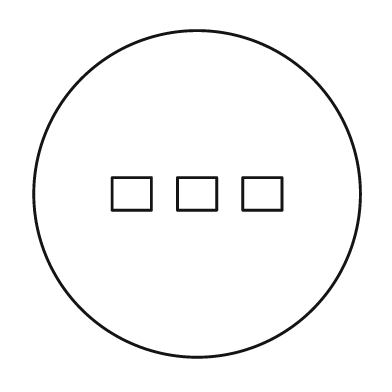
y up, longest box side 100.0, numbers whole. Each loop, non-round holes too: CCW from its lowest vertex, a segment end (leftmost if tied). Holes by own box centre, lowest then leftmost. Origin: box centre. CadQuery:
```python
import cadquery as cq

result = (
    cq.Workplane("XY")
    .moveTo(0.0, 0.0)
    .circle(50.0)
    .moveTo(-26.0, -5.0)
    .lineTo(-14.0, -5.0)
    .lineTo(-14.0, 5.0)
    .lineTo(-26.0, 5.0)
    .close()
    .moveTo(-6.0, -5.0)
    .lineTo(6.0, -5.0)
    .lineTo(6.0, 5.0)
    .lineTo(-6.0, 5.0)
    .close()
    .moveTo(14.0, -5.0)
    .lineTo(26.0, -5.0)
    .lineTo(26.0, 5.0)
    .lineTo(14.0, 5.0)
    .close()
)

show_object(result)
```